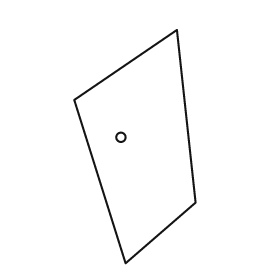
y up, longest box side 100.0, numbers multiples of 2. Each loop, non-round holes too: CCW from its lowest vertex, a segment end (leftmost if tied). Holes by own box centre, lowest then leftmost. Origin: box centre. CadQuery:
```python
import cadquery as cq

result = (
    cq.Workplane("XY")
    .moveTo(-4.0, -50.0)
    .lineTo(26.0, -24.0)
    .lineTo(18.0, 50.0)
    .lineTo(-26.0, 20.0)
    .close()
    .moveTo(-6.0, 4.0)
    .circle(2.0)
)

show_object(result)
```